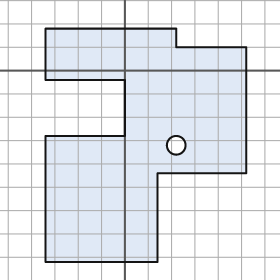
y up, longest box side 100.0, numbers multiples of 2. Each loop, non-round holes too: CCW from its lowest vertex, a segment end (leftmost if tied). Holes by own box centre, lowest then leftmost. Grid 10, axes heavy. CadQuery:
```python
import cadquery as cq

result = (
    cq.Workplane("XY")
    .moveTo(-34.0, -82.0)
    .lineTo(14.0, -82.0)
    .lineTo(14.0, -44.0)
    .lineTo(52.0, -44.0)
    .lineTo(52.0, 10.0)
    .lineTo(22.0, 10.0)
    .lineTo(22.0, 18.0)
    .lineTo(-34.0, 18.0)
    .lineTo(-34.0, -4.0)
    .lineTo(0.0, -4.0)
    .lineTo(0.0, -28.0)
    .lineTo(-34.0, -28.0)
    .close()
    .moveTo(22.0, -32.0)
    .circle(4.0)
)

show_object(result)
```